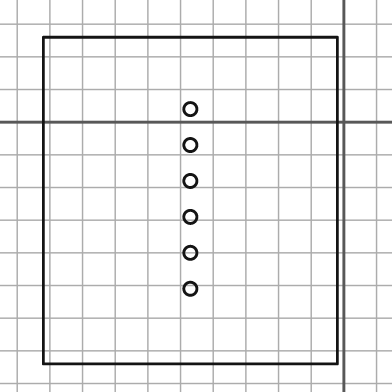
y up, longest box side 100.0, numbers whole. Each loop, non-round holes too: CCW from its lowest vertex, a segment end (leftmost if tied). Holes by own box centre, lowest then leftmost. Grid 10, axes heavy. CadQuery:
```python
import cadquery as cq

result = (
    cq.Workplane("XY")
    .moveTo(-92.0, -74.0)
    .lineTo(-2.0, -74.0)
    .lineTo(-2.0, 26.0)
    .lineTo(-92.0, 26.0)
    .close()
    .moveTo(-47.0, -51.0)
    .circle(2.0)
    .moveTo(-47.0, -40.0)
    .circle(2.0)
    .moveTo(-47.0, -29.0)
    .circle(2.0)
    .moveTo(-47.0, -18.0)
    .circle(2.0)
    .moveTo(-47.0, -7.0)
    .circle(2.0)
    .moveTo(-47.0, 4.0)
    .circle(2.0)
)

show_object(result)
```